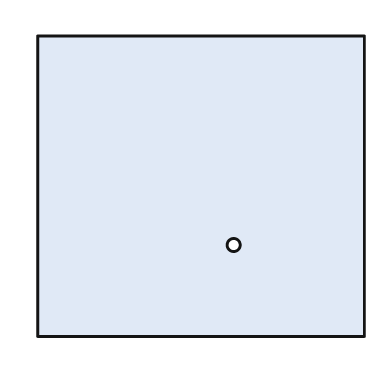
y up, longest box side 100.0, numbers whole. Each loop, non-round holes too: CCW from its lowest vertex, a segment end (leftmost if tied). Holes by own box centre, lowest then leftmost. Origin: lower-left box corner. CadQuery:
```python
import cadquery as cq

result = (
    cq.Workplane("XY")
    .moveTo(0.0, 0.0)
    .lineTo(100.0, 0.0)
    .lineTo(100.0, 92.0)
    .lineTo(0.0, 92.0)
    .close()
    .moveTo(60.0, 28.0)
    .circle(2.0)
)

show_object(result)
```